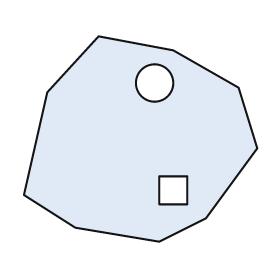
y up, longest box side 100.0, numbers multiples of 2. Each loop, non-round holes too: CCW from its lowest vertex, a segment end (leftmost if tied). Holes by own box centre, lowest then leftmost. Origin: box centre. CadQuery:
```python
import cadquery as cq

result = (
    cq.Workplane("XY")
    .moveTo(8.0, -44.0)
    .lineTo(28.0, -34.0)
    .lineTo(50.0, -4.0)
    .lineTo(42.0, 22.0)
    .lineTo(14.0, 38.0)
    .lineTo(-18.0, 44.0)
    .lineTo(-40.0, 20.0)
    .lineTo(-50.0, -24.0)
    .lineTo(-28.0, -38.0)
    .close()
    .moveTo(8.0, -28.0)
    .lineTo(20.0, -28.0)
    .lineTo(20.0, -16.0)
    .lineTo(8.0, -16.0)
    .close()
    .moveTo(6.0, 24.0)
    .circle(8.0)
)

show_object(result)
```